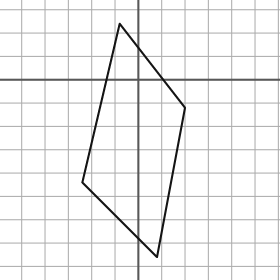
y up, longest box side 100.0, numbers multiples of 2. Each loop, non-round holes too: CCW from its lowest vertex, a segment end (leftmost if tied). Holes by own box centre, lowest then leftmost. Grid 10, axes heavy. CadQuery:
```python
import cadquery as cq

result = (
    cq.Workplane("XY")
    .moveTo(8.0, -76.0)
    .lineTo(20.0, -12.0)
    .lineTo(-8.0, 24.0)
    .lineTo(-24.0, -44.0)
    .close()
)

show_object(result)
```